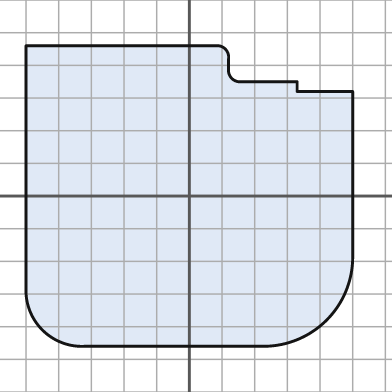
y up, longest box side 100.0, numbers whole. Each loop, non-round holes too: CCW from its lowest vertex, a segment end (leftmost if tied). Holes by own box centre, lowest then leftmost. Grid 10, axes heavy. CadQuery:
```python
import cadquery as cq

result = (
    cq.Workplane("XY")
    .moveTo(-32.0, -46.0)
    .lineTo(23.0, -46.0)
    .threePointArc((42.0, -38.0), (50.0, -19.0))
    .lineTo(50.0, 32.0)
    .lineTo(33.0, 32.0)
    .lineTo(33.0, 35.0)
    .lineTo(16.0, 35.0)
    .threePointArc((13.0, 36.0), (12.0, 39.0))
    .lineTo(12.0, 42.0)
    .threePointArc((11.0, 45.0), (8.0, 46.0))
    .lineTo(-50.0, 46.0)
    .lineTo(-50.0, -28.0)
    .threePointArc((-45.0, -41.0), (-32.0, -46.0))
    .close()
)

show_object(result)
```